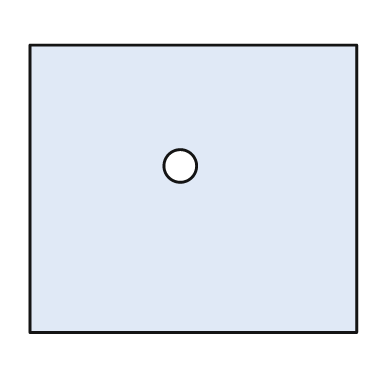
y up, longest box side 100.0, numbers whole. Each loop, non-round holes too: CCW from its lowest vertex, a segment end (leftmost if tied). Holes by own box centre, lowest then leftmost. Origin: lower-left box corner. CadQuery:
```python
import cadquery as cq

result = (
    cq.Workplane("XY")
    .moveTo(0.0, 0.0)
    .lineTo(100.0, 0.0)
    .lineTo(100.0, 88.0)
    .lineTo(0.0, 88.0)
    .close()
    .moveTo(46.0, 51.0)
    .circle(5.0)
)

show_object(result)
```